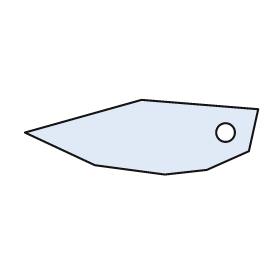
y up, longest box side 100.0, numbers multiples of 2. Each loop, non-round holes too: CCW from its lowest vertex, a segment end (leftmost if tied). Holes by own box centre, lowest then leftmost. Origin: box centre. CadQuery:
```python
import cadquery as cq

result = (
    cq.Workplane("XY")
    .moveTo(10.0, -16.0)
    .lineTo(28.0, -14.0)
    .lineTo(46.0, -6.0)
    .lineTo(50.0, 12.0)
    .lineTo(0.0, 16.0)
    .lineTo(-50.0, 2.0)
    .lineTo(-20.0, -12.0)
    .close()
    .moveTo(36.0, 2.0)
    .circle(4.0)
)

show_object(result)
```